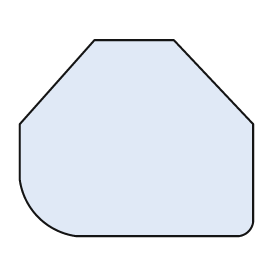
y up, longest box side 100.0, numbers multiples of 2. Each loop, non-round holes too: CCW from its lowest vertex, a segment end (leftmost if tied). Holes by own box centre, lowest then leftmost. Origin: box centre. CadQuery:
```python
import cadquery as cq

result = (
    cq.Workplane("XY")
    .moveTo(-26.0, -42.0)
    .lineTo(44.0, -42.0)
    .threePointArc((48.0, -40.0), (50.0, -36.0))
    .lineTo(50.0, 6.0)
    .lineTo(16.0, 42.0)
    .lineTo(-18.0, 42.0)
    .lineTo(-50.0, 6.0)
    .lineTo(-50.0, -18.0)
    .threePointArc((-42.0, -34.0), (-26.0, -42.0))
    .close()
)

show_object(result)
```